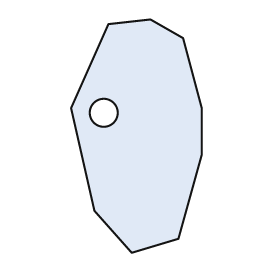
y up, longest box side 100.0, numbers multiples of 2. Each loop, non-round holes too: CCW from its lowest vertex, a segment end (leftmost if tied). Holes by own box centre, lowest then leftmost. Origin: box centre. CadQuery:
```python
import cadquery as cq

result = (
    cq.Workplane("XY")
    .moveTo(-2.0, -50.0)
    .lineTo(18.0, -44.0)
    .lineTo(28.0, -8.0)
    .lineTo(28.0, 12.0)
    .lineTo(20.0, 42.0)
    .lineTo(6.0, 50.0)
    .lineTo(-12.0, 48.0)
    .lineTo(-28.0, 12.0)
    .lineTo(-18.0, -32.0)
    .close()
    .moveTo(-14.0, 10.0)
    .circle(6.0)
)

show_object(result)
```